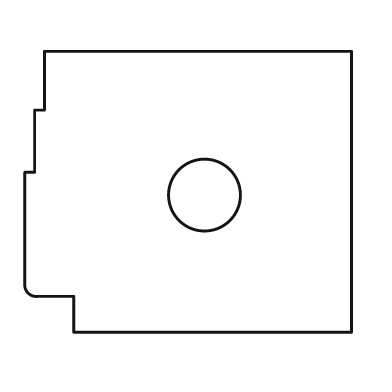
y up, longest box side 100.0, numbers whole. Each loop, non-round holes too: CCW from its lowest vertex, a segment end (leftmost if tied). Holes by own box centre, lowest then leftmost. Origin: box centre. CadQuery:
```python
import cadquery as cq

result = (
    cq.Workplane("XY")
    .moveTo(-35.0, -43.0)
    .lineTo(50.0, -43.0)
    .lineTo(50.0, 43.0)
    .lineTo(-44.0, 43.0)
    .lineTo(-44.0, 25.0)
    .lineTo(-47.0, 25.0)
    .lineTo(-47.0, 6.0)
    .lineTo(-50.0, 6.0)
    .lineTo(-50.0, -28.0)
    .threePointArc((-49.0, -31.0), (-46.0, -32.0))
    .lineTo(-35.0, -32.0)
    .close()
    .moveTo(5.0, -1.0)
    .circle(11.0)
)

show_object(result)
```